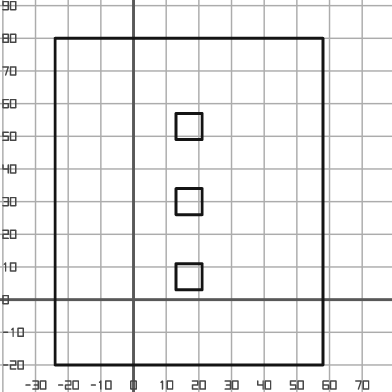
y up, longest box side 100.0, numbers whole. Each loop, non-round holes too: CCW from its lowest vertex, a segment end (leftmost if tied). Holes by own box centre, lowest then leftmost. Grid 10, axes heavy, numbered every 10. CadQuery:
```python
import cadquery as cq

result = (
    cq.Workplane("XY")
    .moveTo(-24.0, -20.0)
    .lineTo(58.0, -20.0)
    .lineTo(58.0, 80.0)
    .lineTo(-24.0, 80.0)
    .close()
    .moveTo(13.0, 3.0)
    .lineTo(21.0, 3.0)
    .lineTo(21.0, 11.0)
    .lineTo(13.0, 11.0)
    .close()
    .moveTo(13.0, 26.0)
    .lineTo(21.0, 26.0)
    .lineTo(21.0, 34.0)
    .lineTo(13.0, 34.0)
    .close()
    .moveTo(13.0, 49.0)
    .lineTo(21.0, 49.0)
    .lineTo(21.0, 57.0)
    .lineTo(13.0, 57.0)
    .close()
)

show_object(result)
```